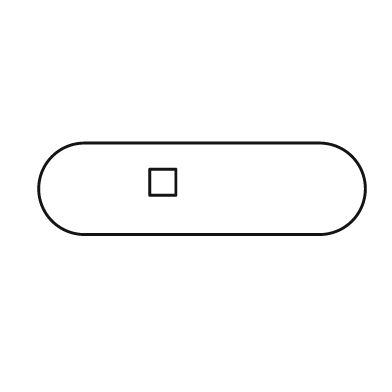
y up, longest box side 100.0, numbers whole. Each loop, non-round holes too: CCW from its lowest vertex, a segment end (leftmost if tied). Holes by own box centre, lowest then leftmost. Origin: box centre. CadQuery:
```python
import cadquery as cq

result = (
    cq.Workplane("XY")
    .moveTo(-36.0, -14.0)
    .lineTo(36.0, -14.0)
    .threePointArc((50.0, 0.0), (36.0, 14.0))
    .lineTo(-36.0, 14.0)
    .threePointArc((-50.0, 0.0), (-36.0, -14.0))
    .close()
    .moveTo(-16.0, -2.0)
    .lineTo(-8.0, -2.0)
    .lineTo(-8.0, 6.0)
    .lineTo(-16.0, 6.0)
    .close()
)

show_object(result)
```